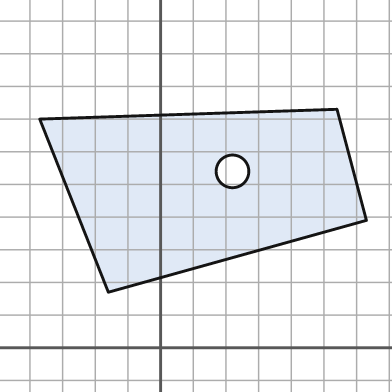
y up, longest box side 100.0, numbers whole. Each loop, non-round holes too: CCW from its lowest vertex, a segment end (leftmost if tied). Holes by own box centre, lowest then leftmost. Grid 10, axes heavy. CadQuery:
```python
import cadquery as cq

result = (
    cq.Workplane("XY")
    .moveTo(-16.0, 17.0)
    .lineTo(63.0, 39.0)
    .lineTo(54.0, 73.0)
    .lineTo(-37.0, 70.0)
    .close()
    .moveTo(22.0, 54.0)
    .circle(5.0)
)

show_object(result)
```